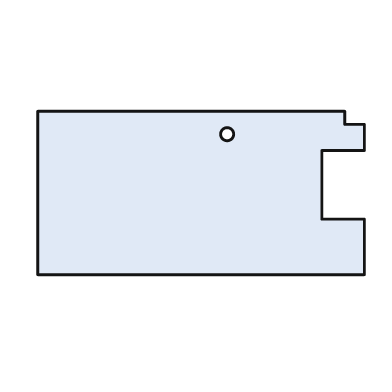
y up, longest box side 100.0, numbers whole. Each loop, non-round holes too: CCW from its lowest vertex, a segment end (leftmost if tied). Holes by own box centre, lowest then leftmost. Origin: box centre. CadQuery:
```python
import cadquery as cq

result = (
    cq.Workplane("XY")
    .moveTo(-50.0, -25.0)
    .lineTo(50.0, -25.0)
    .lineTo(50.0, -8.0)
    .lineTo(37.0, -8.0)
    .lineTo(37.0, 13.0)
    .lineTo(50.0, 13.0)
    .lineTo(50.0, 21.0)
    .lineTo(44.0, 21.0)
    .lineTo(44.0, 25.0)
    .lineTo(-50.0, 25.0)
    .close()
    .moveTo(8.0, 18.0)
    .circle(2.0)
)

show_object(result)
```